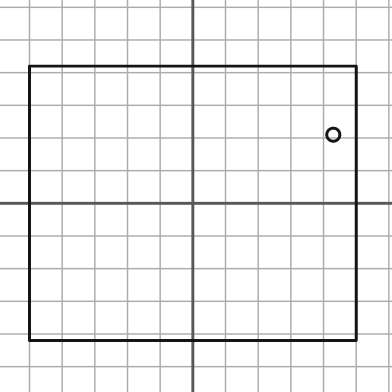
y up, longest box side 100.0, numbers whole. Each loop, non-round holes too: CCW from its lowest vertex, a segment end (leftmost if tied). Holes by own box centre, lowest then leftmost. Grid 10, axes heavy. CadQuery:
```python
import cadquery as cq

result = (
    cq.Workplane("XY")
    .moveTo(-50.0, -42.0)
    .lineTo(50.0, -42.0)
    .lineTo(50.0, 42.0)
    .lineTo(-50.0, 42.0)
    .close()
    .moveTo(43.0, 21.0)
    .circle(2.0)
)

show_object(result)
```